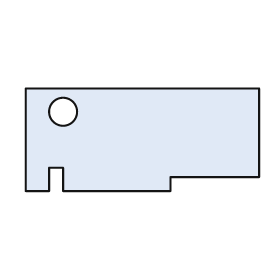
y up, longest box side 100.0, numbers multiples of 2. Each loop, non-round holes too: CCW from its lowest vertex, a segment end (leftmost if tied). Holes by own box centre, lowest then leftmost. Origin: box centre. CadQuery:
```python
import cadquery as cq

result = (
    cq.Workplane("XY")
    .moveTo(-50.0, -22.0)
    .lineTo(-40.0, -22.0)
    .lineTo(-40.0, -12.0)
    .lineTo(-34.0, -12.0)
    .lineTo(-34.0, -22.0)
    .lineTo(12.0, -22.0)
    .lineTo(12.0, -16.0)
    .lineTo(50.0, -16.0)
    .lineTo(50.0, 22.0)
    .lineTo(-50.0, 22.0)
    .close()
    .moveTo(-34.0, 12.0)
    .circle(6.0)
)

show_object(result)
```